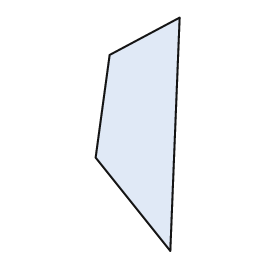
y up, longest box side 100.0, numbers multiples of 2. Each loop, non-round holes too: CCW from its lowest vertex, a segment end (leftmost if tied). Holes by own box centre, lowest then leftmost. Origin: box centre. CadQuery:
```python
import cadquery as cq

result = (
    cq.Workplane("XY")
    .moveTo(14.0, -50.0)
    .lineTo(18.0, 50.0)
    .lineTo(-12.0, 34.0)
    .lineTo(-18.0, -10.0)
    .close()
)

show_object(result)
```